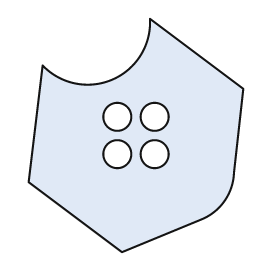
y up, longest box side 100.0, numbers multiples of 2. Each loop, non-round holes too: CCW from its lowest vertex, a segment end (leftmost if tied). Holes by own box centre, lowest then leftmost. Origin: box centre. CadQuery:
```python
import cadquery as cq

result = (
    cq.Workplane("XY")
    .moveTo(-6.0, -50.0)
    .lineTo(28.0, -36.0)
    .threePointArc((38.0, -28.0), (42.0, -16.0))
    .lineTo(46.0, 20.0)
    .lineTo(6.0, 50.0)
    .threePointArc((-10.0, 24.0), (-40.0, 30.0))
    .lineTo(-46.0, -20.0)
    .close()
    .moveTo(-8.0, -8.0)
    .circle(6.0)
    .moveTo(8.0, -8.0)
    .circle(6.0)
    .moveTo(-8.0, 8.0)
    .circle(6.0)
    .moveTo(8.0, 8.0)
    .circle(6.0)
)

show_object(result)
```